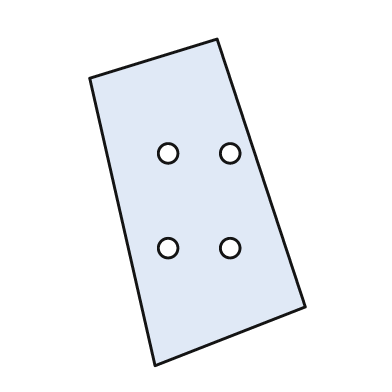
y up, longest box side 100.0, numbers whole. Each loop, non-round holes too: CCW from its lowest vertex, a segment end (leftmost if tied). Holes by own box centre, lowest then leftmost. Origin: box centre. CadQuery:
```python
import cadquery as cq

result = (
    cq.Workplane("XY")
    .moveTo(-13.0, -50.0)
    .lineTo(33.0, -32.0)
    .lineTo(6.0, 50.0)
    .lineTo(-33.0, 38.0)
    .close()
    .moveTo(-9.0, -14.0)
    .circle(3.0)
    .moveTo(10.0, -14.0)
    .circle(3.0)
    .moveTo(-9.0, 15.0)
    .circle(3.0)
    .moveTo(10.0, 15.0)
    .circle(3.0)
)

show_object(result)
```